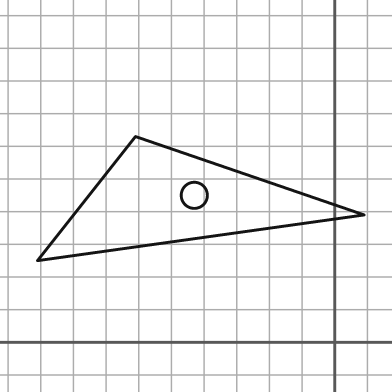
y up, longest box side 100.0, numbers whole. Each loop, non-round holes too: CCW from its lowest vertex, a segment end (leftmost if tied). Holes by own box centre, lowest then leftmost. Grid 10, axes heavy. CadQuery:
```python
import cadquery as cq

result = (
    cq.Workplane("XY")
    .moveTo(-91.0, 25.0)
    .lineTo(9.0, 39.0)
    .lineTo(-61.0, 63.0)
    .close()
    .moveTo(-43.0, 45.0)
    .circle(4.0)
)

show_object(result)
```